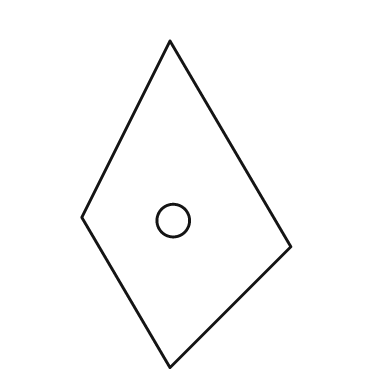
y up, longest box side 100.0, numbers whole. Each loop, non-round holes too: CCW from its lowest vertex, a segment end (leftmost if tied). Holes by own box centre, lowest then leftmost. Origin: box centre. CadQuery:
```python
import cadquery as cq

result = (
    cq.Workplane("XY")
    .moveTo(-5.0, -50.0)
    .lineTo(32.0, -13.0)
    .lineTo(-5.0, 50.0)
    .lineTo(-32.0, -4.0)
    .close()
    .moveTo(-4.0, -5.0)
    .circle(5.0)
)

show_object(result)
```